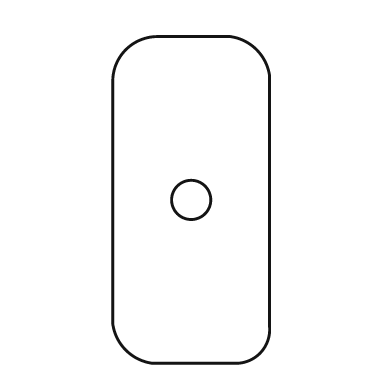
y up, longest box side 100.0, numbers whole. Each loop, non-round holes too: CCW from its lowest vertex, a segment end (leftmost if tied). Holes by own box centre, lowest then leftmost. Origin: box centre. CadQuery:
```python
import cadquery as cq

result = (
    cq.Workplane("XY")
    .moveTo(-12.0, -50.0)
    .lineTo(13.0, -50.0)
    .threePointArc((21.0, -47.0), (24.0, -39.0))
    .lineTo(24.0, 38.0)
    .threePointArc((20.0, 46.0), (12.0, 50.0))
    .lineTo(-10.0, 50.0)
    .threePointArc((-20.0, 46.0), (-24.0, 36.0))
    .lineTo(-24.0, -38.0)
    .threePointArc((-20.0, -46.0), (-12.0, -50.0))
    .close()
    .moveTo(0.0, 0.0)
    .circle(6.0)
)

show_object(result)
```